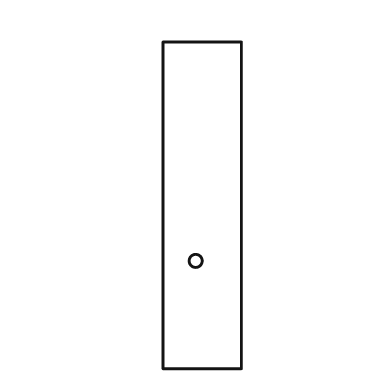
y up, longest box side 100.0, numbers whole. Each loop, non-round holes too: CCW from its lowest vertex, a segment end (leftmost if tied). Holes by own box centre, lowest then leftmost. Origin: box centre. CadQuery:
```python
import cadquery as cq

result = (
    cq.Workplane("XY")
    .moveTo(-12.0, -50.0)
    .lineTo(12.0, -50.0)
    .lineTo(12.0, 50.0)
    .lineTo(-12.0, 50.0)
    .close()
    .moveTo(-2.0, -17.0)
    .circle(2.0)
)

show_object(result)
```